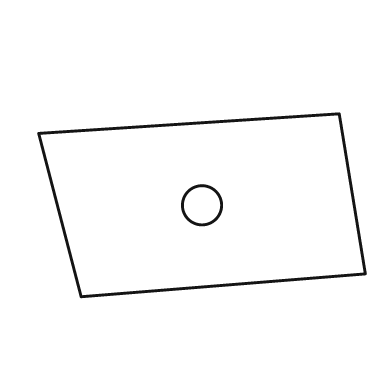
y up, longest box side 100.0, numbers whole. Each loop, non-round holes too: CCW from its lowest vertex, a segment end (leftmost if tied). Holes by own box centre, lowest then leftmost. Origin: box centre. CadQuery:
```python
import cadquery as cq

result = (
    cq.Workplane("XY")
    .moveTo(-37.0, -28.0)
    .lineTo(50.0, -21.0)
    .lineTo(42.0, 28.0)
    .lineTo(-50.0, 22.0)
    .close()
    .moveTo(0.0, 0.0)
    .circle(6.0)
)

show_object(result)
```